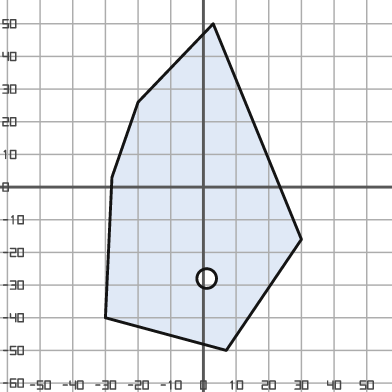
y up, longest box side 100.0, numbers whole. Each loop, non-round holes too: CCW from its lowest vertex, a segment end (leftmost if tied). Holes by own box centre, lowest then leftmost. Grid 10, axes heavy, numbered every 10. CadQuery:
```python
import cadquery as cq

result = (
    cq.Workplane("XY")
    .moveTo(7.0, -50.0)
    .lineTo(30.0, -16.0)
    .lineTo(3.0, 50.0)
    .lineTo(-20.0, 26.0)
    .lineTo(-28.0, 3.0)
    .lineTo(-30.0, -40.0)
    .close()
    .moveTo(1.0, -28.0)
    .circle(3.0)
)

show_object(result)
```